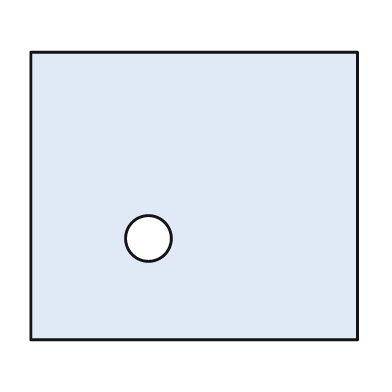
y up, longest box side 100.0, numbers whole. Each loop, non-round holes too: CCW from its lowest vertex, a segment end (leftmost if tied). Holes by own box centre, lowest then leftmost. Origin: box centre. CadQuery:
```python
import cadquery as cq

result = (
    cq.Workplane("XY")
    .moveTo(-50.0, -44.0)
    .lineTo(50.0, -44.0)
    .lineTo(50.0, 44.0)
    .lineTo(-50.0, 44.0)
    .close()
    .moveTo(-14.0, -13.0)
    .circle(7.0)
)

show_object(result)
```